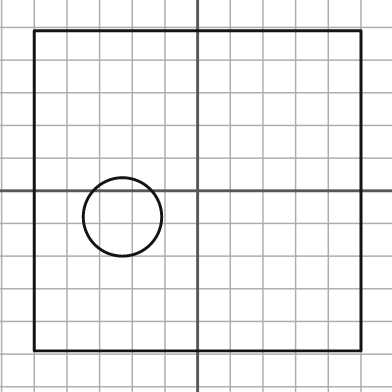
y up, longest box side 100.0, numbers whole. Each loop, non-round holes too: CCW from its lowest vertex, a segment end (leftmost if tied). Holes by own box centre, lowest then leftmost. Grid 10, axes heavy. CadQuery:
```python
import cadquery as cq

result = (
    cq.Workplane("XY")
    .moveTo(-50.0, -49.0)
    .lineTo(50.0, -49.0)
    .lineTo(50.0, 49.0)
    .lineTo(-50.0, 49.0)
    .close()
    .moveTo(-23.0, -8.0)
    .circle(12.0)
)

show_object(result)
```